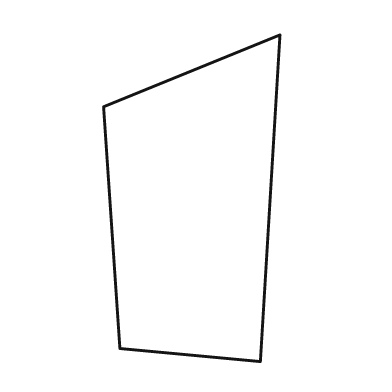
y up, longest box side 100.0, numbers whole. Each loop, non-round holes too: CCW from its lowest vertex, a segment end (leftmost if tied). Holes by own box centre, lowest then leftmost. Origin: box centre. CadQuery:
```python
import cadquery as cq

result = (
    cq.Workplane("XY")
    .moveTo(21.0, -50.0)
    .lineTo(27.0, 50.0)
    .lineTo(-27.0, 28.0)
    .lineTo(-22.0, -46.0)
    .close()
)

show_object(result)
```